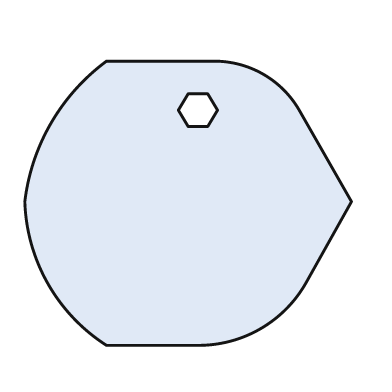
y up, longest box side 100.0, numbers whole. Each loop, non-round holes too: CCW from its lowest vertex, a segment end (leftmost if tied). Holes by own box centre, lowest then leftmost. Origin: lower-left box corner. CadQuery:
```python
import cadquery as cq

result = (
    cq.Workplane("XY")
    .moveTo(25.0, 0.0)
    .lineTo(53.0, 0.0)
    .threePointArc((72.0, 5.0), (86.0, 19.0))
    .lineTo(100.0, 44.0)
    .lineTo(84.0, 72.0)
    .threePointArc((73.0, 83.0), (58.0, 87.0))
    .lineTo(25.0, 87.0)
    .threePointArc((8.0, 68.0), (0.0, 44.0))
    .threePointArc((7.0, 19.0), (25.0, 0.0))
    .close()
    .moveTo(50.0, 67.0)
    .lineTo(56.0, 67.0)
    .lineTo(59.0, 72.0)
    .lineTo(56.0, 77.0)
    .lineTo(50.0, 77.0)
    .lineTo(47.0, 72.0)
    .close()
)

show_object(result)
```